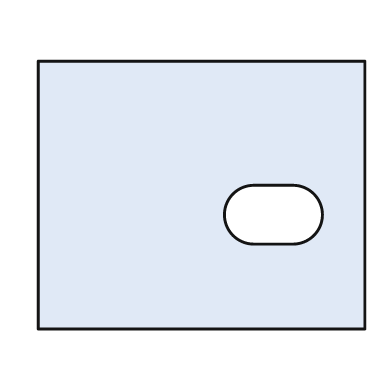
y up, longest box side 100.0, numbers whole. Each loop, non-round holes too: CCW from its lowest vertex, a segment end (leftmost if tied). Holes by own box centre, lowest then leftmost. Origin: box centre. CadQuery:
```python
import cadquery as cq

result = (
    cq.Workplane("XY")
    .moveTo(-50.0, -41.0)
    .lineTo(50.0, -41.0)
    .lineTo(50.0, 41.0)
    .lineTo(-50.0, 41.0)
    .close()
    .moveTo(16.0, -15.0)
    .lineTo(28.0, -15.0)
    .threePointArc((37.0, -6.0), (28.0, 3.0))
    .lineTo(16.0, 3.0)
    .threePointArc((7.0, -6.0), (16.0, -15.0))
    .close()
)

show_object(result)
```